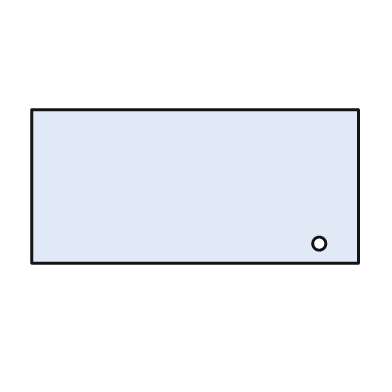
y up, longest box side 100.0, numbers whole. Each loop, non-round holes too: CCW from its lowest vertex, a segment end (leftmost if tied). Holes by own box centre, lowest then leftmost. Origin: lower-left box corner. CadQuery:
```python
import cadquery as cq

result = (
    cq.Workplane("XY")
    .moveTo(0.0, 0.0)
    .lineTo(100.0, 0.0)
    .lineTo(100.0, 47.0)
    .lineTo(0.0, 47.0)
    .close()
    .moveTo(88.0, 6.0)
    .circle(2.0)
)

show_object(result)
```